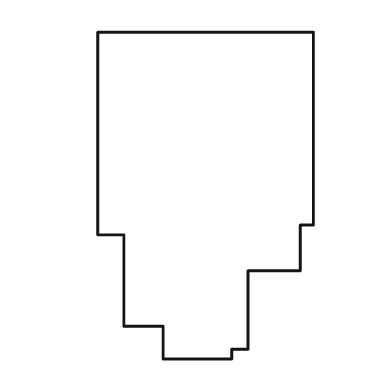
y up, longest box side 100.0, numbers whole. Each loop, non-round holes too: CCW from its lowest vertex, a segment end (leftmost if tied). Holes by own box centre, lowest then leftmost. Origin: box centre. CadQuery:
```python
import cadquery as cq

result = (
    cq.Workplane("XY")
    .moveTo(-13.0, -50.0)
    .lineTo(8.0, -50.0)
    .lineTo(8.0, -47.0)
    .lineTo(13.0, -47.0)
    .lineTo(13.0, -23.0)
    .lineTo(29.0, -23.0)
    .lineTo(29.0, -9.0)
    .lineTo(33.0, -9.0)
    .lineTo(33.0, 50.0)
    .lineTo(-33.0, 50.0)
    .lineTo(-33.0, -12.0)
    .lineTo(-25.0, -12.0)
    .lineTo(-25.0, -40.0)
    .lineTo(-13.0, -40.0)
    .close()
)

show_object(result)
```